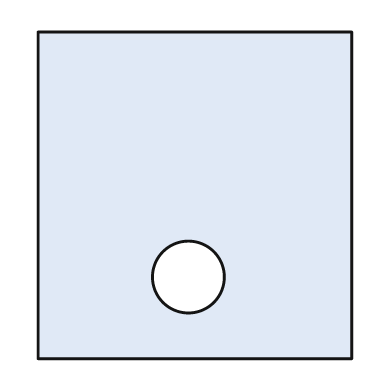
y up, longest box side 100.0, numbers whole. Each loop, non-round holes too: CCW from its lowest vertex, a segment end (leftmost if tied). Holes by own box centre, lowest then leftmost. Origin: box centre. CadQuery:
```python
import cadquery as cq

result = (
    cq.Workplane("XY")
    .moveTo(-48.0, -50.0)
    .lineTo(48.0, -50.0)
    .lineTo(48.0, 50.0)
    .lineTo(-48.0, 50.0)
    .close()
    .moveTo(-2.0, -25.0)
    .circle(11.0)
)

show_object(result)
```